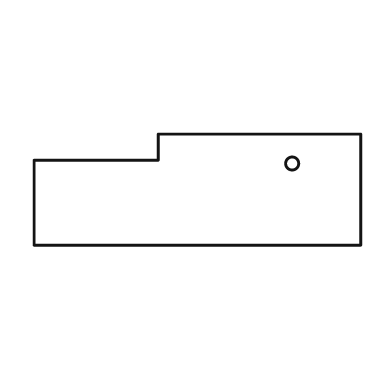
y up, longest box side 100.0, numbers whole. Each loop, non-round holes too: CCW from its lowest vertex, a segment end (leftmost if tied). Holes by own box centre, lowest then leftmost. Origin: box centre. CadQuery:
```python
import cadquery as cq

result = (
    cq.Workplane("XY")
    .moveTo(-50.0, -17.0)
    .lineTo(50.0, -17.0)
    .lineTo(50.0, 17.0)
    .lineTo(-12.0, 17.0)
    .lineTo(-12.0, 9.0)
    .lineTo(-50.0, 9.0)
    .close()
    .moveTo(29.0, 8.0)
    .circle(2.0)
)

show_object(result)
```